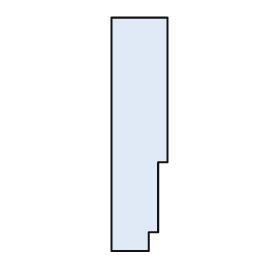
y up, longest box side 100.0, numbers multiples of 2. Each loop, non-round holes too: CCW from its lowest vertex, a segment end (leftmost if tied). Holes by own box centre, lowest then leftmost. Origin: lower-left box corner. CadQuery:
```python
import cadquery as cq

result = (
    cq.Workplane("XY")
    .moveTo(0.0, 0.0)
    .lineTo(16.0, 0.0)
    .lineTo(16.0, 8.0)
    .lineTo(20.0, 8.0)
    .lineTo(20.0, 38.0)
    .lineTo(24.0, 38.0)
    .lineTo(24.0, 100.0)
    .lineTo(0.0, 100.0)
    .close()
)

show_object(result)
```